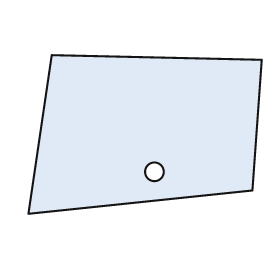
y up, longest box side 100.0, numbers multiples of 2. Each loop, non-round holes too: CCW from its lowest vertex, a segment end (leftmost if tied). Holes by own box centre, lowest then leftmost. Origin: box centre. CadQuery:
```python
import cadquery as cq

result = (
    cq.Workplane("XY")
    .moveTo(-50.0, -34.0)
    .lineTo(46.0, -24.0)
    .lineTo(50.0, 32.0)
    .lineTo(-40.0, 34.0)
    .close()
    .moveTo(4.0, -16.0)
    .circle(4.0)
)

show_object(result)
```